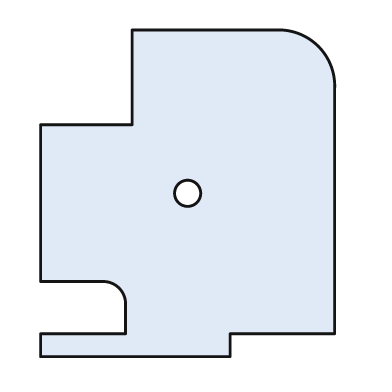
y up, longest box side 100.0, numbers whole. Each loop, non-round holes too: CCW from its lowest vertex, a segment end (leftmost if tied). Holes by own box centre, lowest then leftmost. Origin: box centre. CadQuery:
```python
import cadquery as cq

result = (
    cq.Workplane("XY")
    .moveTo(-45.0, -50.0)
    .lineTo(13.0, -50.0)
    .lineTo(13.0, -43.0)
    .lineTo(45.0, -43.0)
    .lineTo(45.0, 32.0)
    .threePointArc((40.0, 45.0), (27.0, 50.0))
    .lineTo(-17.0, 50.0)
    .lineTo(-17.0, 21.0)
    .lineTo(-45.0, 21.0)
    .lineTo(-45.0, -27.0)
    .lineTo(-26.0, -27.0)
    .threePointArc((-21.0, -29.0), (-19.0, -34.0))
    .lineTo(-19.0, -43.0)
    .lineTo(-45.0, -43.0)
    .close()
    .moveTo(0.0, 0.0)
    .circle(4.0)
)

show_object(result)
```